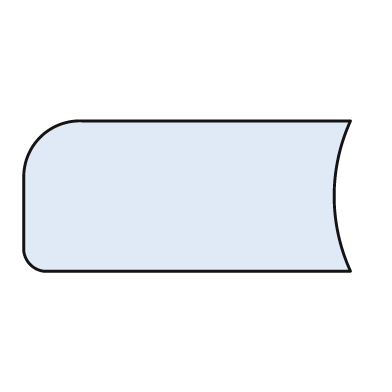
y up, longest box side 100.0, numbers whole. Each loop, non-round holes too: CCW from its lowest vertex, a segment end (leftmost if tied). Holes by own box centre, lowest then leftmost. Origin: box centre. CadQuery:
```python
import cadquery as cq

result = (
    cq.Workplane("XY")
    .moveTo(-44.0, -23.0)
    .lineTo(50.0, -23.0)
    .threePointArc((45.0, 0.0), (50.0, 23.0))
    .lineTo(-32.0, 23.0)
    .threePointArc((-45.0, 18.0), (-50.0, 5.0))
    .lineTo(-50.0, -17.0)
    .threePointArc((-48.0, -21.0), (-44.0, -23.0))
    .close()
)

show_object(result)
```